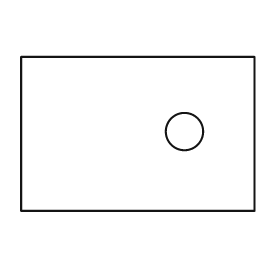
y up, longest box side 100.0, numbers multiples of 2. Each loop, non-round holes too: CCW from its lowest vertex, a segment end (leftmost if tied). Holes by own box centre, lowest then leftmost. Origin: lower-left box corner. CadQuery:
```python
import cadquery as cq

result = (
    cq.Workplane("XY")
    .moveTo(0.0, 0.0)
    .lineTo(100.0, 0.0)
    .lineTo(100.0, 66.0)
    .lineTo(0.0, 66.0)
    .close()
    .moveTo(70.0, 34.0)
    .circle(8.0)
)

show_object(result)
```